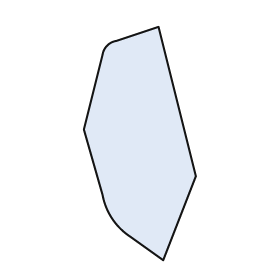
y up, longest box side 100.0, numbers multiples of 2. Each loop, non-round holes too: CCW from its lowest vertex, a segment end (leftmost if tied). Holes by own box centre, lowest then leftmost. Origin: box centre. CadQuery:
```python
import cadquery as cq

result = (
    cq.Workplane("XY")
    .moveTo(10.0, -50.0)
    .lineTo(24.0, -14.0)
    .lineTo(8.0, 50.0)
    .lineTo(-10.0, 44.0)
    .threePointArc((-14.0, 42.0), (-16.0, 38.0))
    .lineTo(-24.0, 6.0)
    .lineTo(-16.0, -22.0)
    .threePointArc((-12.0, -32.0), (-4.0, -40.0))
    .close()
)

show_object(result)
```